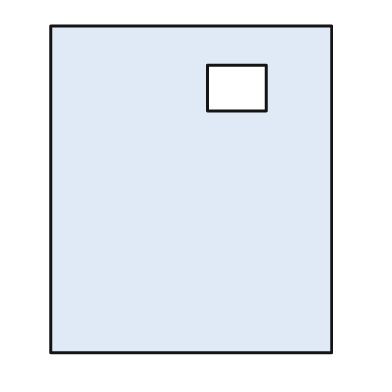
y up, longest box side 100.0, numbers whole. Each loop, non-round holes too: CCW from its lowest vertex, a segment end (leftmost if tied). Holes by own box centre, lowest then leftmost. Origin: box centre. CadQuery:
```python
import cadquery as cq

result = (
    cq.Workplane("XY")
    .moveTo(-43.0, -50.0)
    .lineTo(43.0, -50.0)
    .lineTo(43.0, 50.0)
    .lineTo(-43.0, 50.0)
    .close()
    .moveTo(5.0, 24.0)
    .lineTo(23.0, 24.0)
    .lineTo(23.0, 38.0)
    .lineTo(5.0, 38.0)
    .close()
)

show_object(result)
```